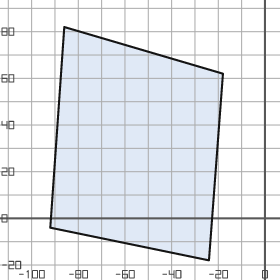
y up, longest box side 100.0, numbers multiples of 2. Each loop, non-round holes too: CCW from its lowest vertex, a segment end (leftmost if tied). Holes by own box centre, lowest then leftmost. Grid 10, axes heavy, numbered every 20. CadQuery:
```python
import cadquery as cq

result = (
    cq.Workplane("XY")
    .moveTo(-24.0, -18.0)
    .lineTo(-18.0, 62.0)
    .lineTo(-86.0, 82.0)
    .lineTo(-92.0, -4.0)
    .close()
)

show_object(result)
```